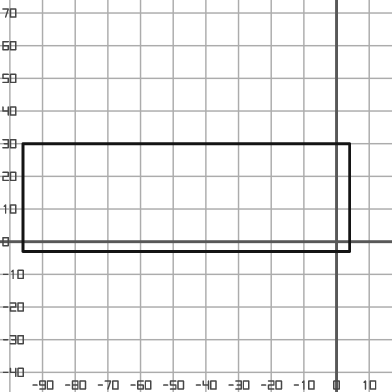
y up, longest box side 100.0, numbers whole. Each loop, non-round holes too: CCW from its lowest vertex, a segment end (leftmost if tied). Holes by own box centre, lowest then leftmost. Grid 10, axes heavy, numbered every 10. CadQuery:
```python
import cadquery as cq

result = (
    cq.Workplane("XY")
    .moveTo(-96.0, -3.0)
    .lineTo(4.0, -3.0)
    .lineTo(4.0, 30.0)
    .lineTo(-96.0, 30.0)
    .close()
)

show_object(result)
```